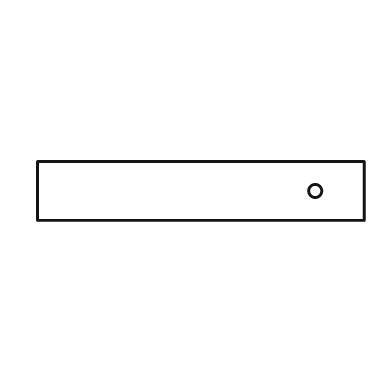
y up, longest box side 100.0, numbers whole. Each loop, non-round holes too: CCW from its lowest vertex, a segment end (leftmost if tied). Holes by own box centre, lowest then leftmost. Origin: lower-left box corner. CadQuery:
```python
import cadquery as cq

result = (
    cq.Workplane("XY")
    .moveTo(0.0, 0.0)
    .lineTo(100.0, 0.0)
    .lineTo(100.0, 18.0)
    .lineTo(0.0, 18.0)
    .close()
    .moveTo(85.0, 9.0)
    .circle(2.0)
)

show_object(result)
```